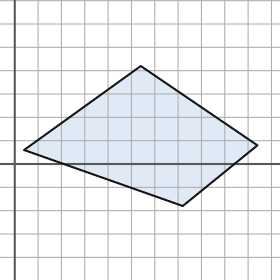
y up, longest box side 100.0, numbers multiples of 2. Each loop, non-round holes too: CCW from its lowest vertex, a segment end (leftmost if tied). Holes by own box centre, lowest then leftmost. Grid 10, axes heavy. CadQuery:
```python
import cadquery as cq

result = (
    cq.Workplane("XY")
    .moveTo(72.0, -18.0)
    .lineTo(104.0, 8.0)
    .lineTo(54.0, 42.0)
    .lineTo(4.0, 6.0)
    .close()
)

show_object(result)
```